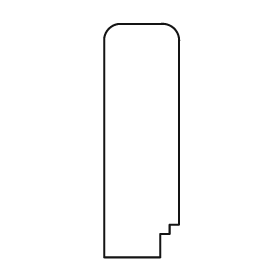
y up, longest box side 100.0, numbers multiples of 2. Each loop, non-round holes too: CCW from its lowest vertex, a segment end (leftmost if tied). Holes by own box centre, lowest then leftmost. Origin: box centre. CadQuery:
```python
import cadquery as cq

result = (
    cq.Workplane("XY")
    .moveTo(-16.0, -50.0)
    .lineTo(8.0, -50.0)
    .lineTo(8.0, -40.0)
    .lineTo(12.0, -40.0)
    .lineTo(12.0, -36.0)
    .lineTo(16.0, -36.0)
    .lineTo(16.0, 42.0)
    .threePointArc((14.0, 48.0), (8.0, 50.0))
    .lineTo(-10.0, 50.0)
    .threePointArc((-14.0, 48.0), (-16.0, 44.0))
    .close()
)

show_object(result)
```